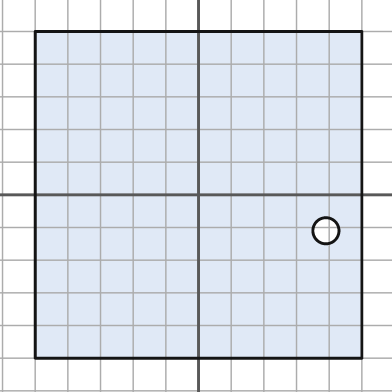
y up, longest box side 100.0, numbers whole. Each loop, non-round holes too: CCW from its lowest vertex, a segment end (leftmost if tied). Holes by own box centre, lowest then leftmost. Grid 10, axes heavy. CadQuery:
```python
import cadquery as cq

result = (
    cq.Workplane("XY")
    .moveTo(-50.0, -50.0)
    .lineTo(50.0, -50.0)
    .lineTo(50.0, 50.0)
    .lineTo(-50.0, 50.0)
    .close()
    .moveTo(39.0, -11.0)
    .circle(4.0)
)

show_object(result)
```